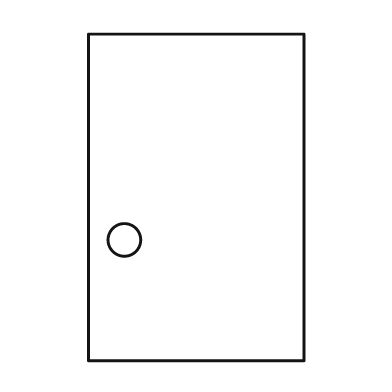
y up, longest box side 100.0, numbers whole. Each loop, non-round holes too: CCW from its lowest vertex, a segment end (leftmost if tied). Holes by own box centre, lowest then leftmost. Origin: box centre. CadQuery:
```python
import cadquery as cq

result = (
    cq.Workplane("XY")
    .moveTo(-33.0, -50.0)
    .lineTo(33.0, -50.0)
    .lineTo(33.0, 50.0)
    .lineTo(-33.0, 50.0)
    .close()
    .moveTo(-22.0, -13.0)
    .circle(5.0)
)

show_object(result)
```